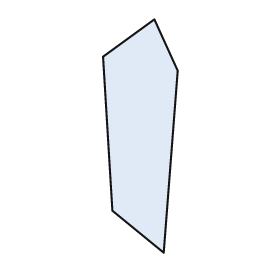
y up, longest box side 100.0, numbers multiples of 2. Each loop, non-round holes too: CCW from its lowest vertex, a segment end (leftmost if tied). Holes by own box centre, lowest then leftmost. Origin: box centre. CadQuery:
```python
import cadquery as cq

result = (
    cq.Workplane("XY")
    .moveTo(10.0, -50.0)
    .lineTo(16.0, 28.0)
    .lineTo(6.0, 50.0)
    .lineTo(-16.0, 34.0)
    .lineTo(-12.0, -32.0)
    .close()
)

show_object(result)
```